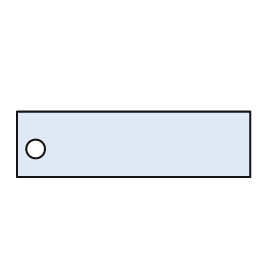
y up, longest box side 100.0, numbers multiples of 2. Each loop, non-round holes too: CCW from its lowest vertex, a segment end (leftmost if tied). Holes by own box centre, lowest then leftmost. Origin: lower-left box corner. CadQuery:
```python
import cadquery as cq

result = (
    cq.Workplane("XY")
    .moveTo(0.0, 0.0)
    .lineTo(100.0, 0.0)
    .lineTo(100.0, 28.0)
    .lineTo(0.0, 28.0)
    .close()
    .moveTo(8.0, 12.0)
    .circle(4.0)
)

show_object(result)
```